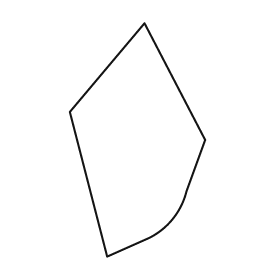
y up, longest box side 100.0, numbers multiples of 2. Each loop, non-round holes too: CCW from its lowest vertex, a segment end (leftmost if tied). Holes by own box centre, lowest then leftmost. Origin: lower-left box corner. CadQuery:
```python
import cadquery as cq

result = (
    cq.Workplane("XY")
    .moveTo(16.0, 0.0)
    .lineTo(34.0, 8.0)
    .threePointArc((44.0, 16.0), (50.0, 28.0))
    .lineTo(58.0, 50.0)
    .lineTo(32.0, 100.0)
    .lineTo(0.0, 62.0)
    .close()
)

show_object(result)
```